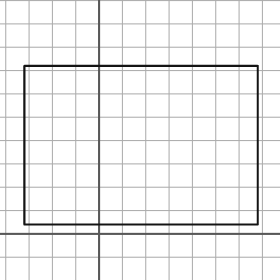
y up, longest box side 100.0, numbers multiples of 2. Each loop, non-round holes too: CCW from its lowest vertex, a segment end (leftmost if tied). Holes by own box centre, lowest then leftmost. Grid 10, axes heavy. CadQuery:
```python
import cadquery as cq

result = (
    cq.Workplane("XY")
    .moveTo(-32.0, 4.0)
    .lineTo(68.0, 4.0)
    .lineTo(68.0, 72.0)
    .lineTo(-32.0, 72.0)
    .close()
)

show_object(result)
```